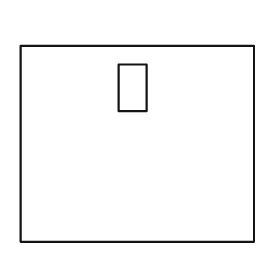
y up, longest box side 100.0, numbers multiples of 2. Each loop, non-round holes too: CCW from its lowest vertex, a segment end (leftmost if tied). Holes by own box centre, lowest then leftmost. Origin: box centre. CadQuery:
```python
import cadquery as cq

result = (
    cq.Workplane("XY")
    .moveTo(-50.0, -42.0)
    .lineTo(50.0, -42.0)
    .lineTo(50.0, 42.0)
    .lineTo(-50.0, 42.0)
    .close()
    .moveTo(-8.0, 14.0)
    .lineTo(4.0, 14.0)
    .lineTo(4.0, 34.0)
    .lineTo(-8.0, 34.0)
    .close()
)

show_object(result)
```